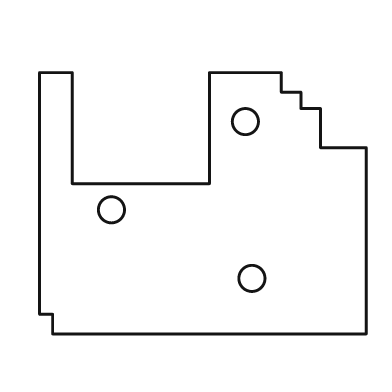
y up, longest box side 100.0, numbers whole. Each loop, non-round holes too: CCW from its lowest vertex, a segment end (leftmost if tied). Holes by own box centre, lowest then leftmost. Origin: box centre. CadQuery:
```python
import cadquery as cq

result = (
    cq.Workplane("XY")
    .moveTo(-46.0, -40.0)
    .lineTo(50.0, -40.0)
    .lineTo(50.0, 17.0)
    .lineTo(36.0, 17.0)
    .lineTo(36.0, 29.0)
    .lineTo(30.0, 29.0)
    .lineTo(30.0, 34.0)
    .lineTo(24.0, 34.0)
    .lineTo(24.0, 40.0)
    .lineTo(2.0, 40.0)
    .lineTo(2.0, 6.0)
    .lineTo(-40.0, 6.0)
    .lineTo(-40.0, 40.0)
    .lineTo(-50.0, 40.0)
    .lineTo(-50.0, -34.0)
    .lineTo(-46.0, -34.0)
    .close()
    .moveTo(15.0, -23.0)
    .circle(4.0)
    .moveTo(-28.0, -2.0)
    .circle(4.0)
    .moveTo(13.0, 25.0)
    .circle(4.0)
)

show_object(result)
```